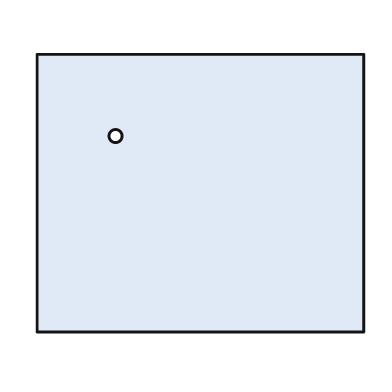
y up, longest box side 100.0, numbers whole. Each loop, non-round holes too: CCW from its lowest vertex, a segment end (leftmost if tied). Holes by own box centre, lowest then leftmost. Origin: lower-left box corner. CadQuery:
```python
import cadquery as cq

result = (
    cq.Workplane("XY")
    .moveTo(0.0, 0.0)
    .lineTo(100.0, 0.0)
    .lineTo(100.0, 85.0)
    .lineTo(0.0, 85.0)
    .close()
    .moveTo(24.0, 60.0)
    .circle(2.0)
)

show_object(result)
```